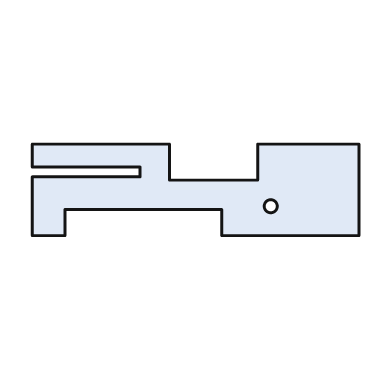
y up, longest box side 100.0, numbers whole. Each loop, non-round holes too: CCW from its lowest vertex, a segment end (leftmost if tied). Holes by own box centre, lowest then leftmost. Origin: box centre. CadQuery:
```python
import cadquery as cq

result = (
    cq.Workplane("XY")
    .moveTo(-50.0, -14.0)
    .lineTo(-40.0, -14.0)
    .lineTo(-40.0, -6.0)
    .lineTo(8.0, -6.0)
    .lineTo(8.0, -14.0)
    .lineTo(50.0, -14.0)
    .lineTo(50.0, 14.0)
    .lineTo(19.0, 14.0)
    .lineTo(19.0, 3.0)
    .lineTo(-8.0, 3.0)
    .lineTo(-8.0, 14.0)
    .lineTo(-50.0, 14.0)
    .lineTo(-50.0, 7.0)
    .lineTo(-17.0, 7.0)
    .lineTo(-17.0, 4.0)
    .lineTo(-50.0, 4.0)
    .close()
    .moveTo(23.0, -5.0)
    .circle(2.0)
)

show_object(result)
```